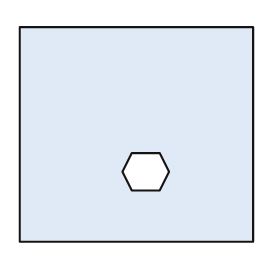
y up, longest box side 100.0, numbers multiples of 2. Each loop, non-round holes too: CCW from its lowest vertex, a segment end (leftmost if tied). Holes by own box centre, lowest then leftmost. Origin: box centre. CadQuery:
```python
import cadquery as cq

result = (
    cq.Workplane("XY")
    .moveTo(-50.0, -46.0)
    .lineTo(50.0, -46.0)
    .lineTo(50.0, 46.0)
    .lineTo(-50.0, 46.0)
    .close()
    .moveTo(-2.0, -24.0)
    .lineTo(10.0, -24.0)
    .lineTo(14.0, -16.0)
    .lineTo(10.0, -8.0)
    .lineTo(-2.0, -8.0)
    .lineTo(-6.0, -16.0)
    .close()
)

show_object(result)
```